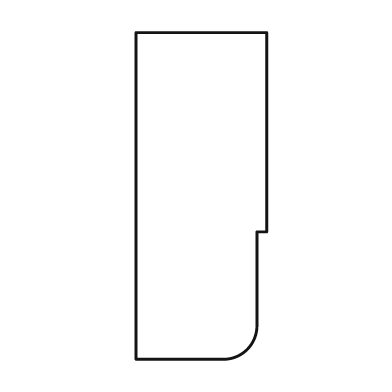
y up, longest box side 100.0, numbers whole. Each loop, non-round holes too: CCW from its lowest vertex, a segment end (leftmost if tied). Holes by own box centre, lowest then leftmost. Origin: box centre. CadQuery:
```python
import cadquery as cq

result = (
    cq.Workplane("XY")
    .moveTo(-20.0, -50.0)
    .lineTo(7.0, -50.0)
    .threePointArc((14.0, -47.0), (17.0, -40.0))
    .lineTo(17.0, -11.0)
    .lineTo(20.0, -11.0)
    .lineTo(20.0, 50.0)
    .lineTo(-20.0, 50.0)
    .close()
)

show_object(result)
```